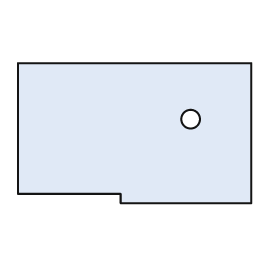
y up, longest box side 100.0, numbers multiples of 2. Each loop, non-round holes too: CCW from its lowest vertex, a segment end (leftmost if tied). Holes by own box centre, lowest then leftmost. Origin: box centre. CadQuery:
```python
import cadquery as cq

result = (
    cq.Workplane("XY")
    .moveTo(-6.0, -30.0)
    .lineTo(50.0, -30.0)
    .lineTo(50.0, 30.0)
    .lineTo(-50.0, 30.0)
    .lineTo(-50.0, -26.0)
    .lineTo(-6.0, -26.0)
    .close()
    .moveTo(24.0, 6.0)
    .circle(4.0)
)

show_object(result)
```